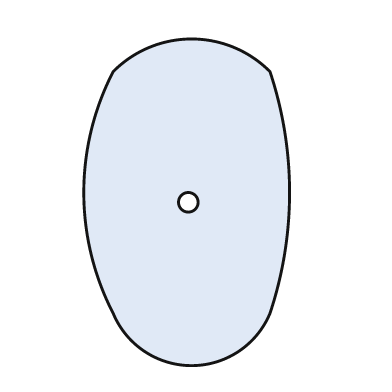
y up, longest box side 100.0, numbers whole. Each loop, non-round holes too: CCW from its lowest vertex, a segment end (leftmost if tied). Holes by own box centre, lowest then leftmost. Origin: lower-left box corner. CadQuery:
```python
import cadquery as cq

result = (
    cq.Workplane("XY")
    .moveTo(9.0, 16.0)
    .threePointArc((33.0, 0.0), (57.0, 16.0))
    .threePointArc((63.0, 53.0), (57.0, 90.0))
    .threePointArc((33.0, 100.0), (9.0, 90.0))
    .threePointArc((0.0, 53.0), (9.0, 16.0))
    .close()
    .moveTo(32.0, 50.0)
    .circle(3.0)
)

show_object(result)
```